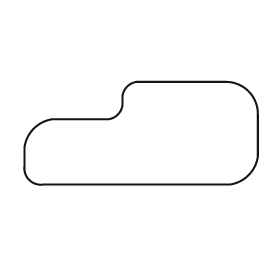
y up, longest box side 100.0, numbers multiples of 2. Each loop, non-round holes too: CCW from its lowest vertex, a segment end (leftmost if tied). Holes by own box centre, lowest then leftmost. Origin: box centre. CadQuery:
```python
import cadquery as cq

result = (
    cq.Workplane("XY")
    .moveTo(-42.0, -22.0)
    .lineTo(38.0, -22.0)
    .threePointArc((46.0, -18.0), (50.0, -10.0))
    .lineTo(50.0, 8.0)
    .threePointArc((46.0, 18.0), (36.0, 22.0))
    .lineTo(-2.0, 22.0)
    .threePointArc((-6.0, 20.0), (-8.0, 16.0))
    .lineTo(-8.0, 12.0)
    .threePointArc((-10.0, 8.0), (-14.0, 6.0))
    .lineTo(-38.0, 6.0)
    .threePointArc((-46.0, 2.0), (-50.0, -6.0))
    .lineTo(-50.0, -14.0)
    .threePointArc((-48.0, -20.0), (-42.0, -22.0))
    .close()
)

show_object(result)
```